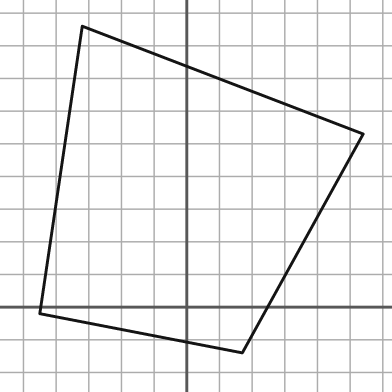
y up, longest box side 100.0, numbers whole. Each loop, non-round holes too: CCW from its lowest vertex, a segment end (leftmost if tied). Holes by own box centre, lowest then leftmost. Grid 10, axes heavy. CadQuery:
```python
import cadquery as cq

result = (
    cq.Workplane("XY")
    .moveTo(17.0, -14.0)
    .lineTo(54.0, 53.0)
    .lineTo(-32.0, 86.0)
    .lineTo(-45.0, -2.0)
    .close()
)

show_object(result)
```